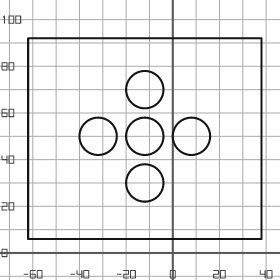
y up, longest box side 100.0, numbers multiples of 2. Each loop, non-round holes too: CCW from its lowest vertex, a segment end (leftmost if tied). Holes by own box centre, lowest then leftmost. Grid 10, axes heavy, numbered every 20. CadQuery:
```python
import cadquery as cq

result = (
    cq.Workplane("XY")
    .moveTo(-62.0, 6.0)
    .lineTo(38.0, 6.0)
    .lineTo(38.0, 92.0)
    .lineTo(-62.0, 92.0)
    .close()
    .moveTo(-12.0, 30.0)
    .circle(8.0)
    .moveTo(-32.0, 50.0)
    .circle(8.0)
    .moveTo(-12.0, 50.0)
    .circle(8.0)
    .moveTo(8.0, 50.0)
    .circle(8.0)
    .moveTo(-12.0, 70.0)
    .circle(8.0)
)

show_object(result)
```